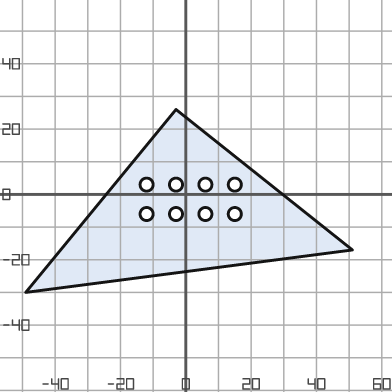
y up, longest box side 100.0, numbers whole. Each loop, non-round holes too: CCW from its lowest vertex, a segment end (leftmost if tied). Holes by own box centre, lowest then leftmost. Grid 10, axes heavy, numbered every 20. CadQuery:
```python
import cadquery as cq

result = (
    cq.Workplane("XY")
    .moveTo(-49.0, -30.0)
    .lineTo(51.0, -17.0)
    .lineTo(-3.0, 26.0)
    .close()
    .moveTo(-12.0, -6.0)
    .circle(2.0)
    .moveTo(-3.0, -6.0)
    .circle(2.0)
    .moveTo(6.0, -6.0)
    .circle(2.0)
    .moveTo(15.0, -6.0)
    .circle(2.0)
    .moveTo(-12.0, 3.0)
    .circle(2.0)
    .moveTo(-3.0, 3.0)
    .circle(2.0)
    .moveTo(6.0, 3.0)
    .circle(2.0)
    .moveTo(15.0, 3.0)
    .circle(2.0)
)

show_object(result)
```